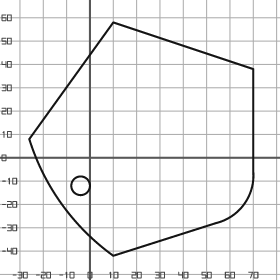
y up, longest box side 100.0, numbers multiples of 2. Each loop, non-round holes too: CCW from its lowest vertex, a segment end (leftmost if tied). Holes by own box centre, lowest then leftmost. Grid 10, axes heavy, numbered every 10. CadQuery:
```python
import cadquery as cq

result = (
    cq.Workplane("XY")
    .moveTo(10.0, -42.0)
    .lineTo(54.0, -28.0)
    .threePointArc((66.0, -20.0), (70.0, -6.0))
    .lineTo(70.0, 38.0)
    .lineTo(10.0, 58.0)
    .lineTo(-26.0, 8.0)
    .threePointArc((-12.0, -20.0), (10.0, -42.0))
    .close()
    .moveTo(-4.0, -12.0)
    .circle(4.0)
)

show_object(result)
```